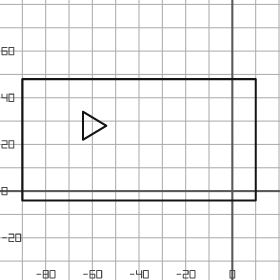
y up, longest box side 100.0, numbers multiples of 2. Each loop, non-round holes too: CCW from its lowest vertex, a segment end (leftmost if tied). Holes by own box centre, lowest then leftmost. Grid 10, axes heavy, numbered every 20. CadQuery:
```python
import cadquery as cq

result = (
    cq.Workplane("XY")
    .moveTo(-90.0, -4.0)
    .lineTo(10.0, -4.0)
    .lineTo(10.0, 48.0)
    .lineTo(-90.0, 48.0)
    .close()
    .moveTo(-64.0, 22.0)
    .lineTo(-54.0, 28.0)
    .lineTo(-64.0, 34.0)
    .close()
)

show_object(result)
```